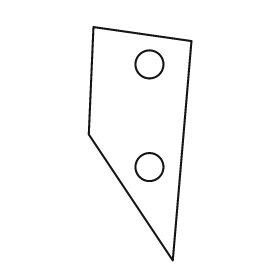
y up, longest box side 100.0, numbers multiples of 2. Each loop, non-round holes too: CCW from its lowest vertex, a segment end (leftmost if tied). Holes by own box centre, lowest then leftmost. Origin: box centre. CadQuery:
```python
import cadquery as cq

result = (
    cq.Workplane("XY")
    .moveTo(14.0, -50.0)
    .lineTo(22.0, 44.0)
    .lineTo(-20.0, 50.0)
    .lineTo(-22.0, 4.0)
    .close()
    .moveTo(4.0, -10.0)
    .circle(6.0)
    .moveTo(4.0, 34.0)
    .circle(6.0)
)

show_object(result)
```